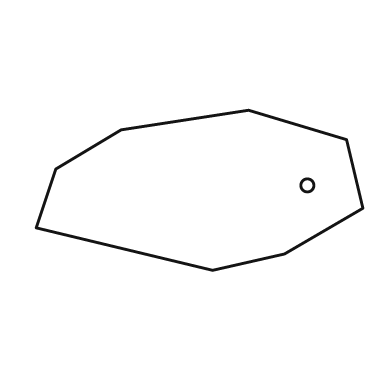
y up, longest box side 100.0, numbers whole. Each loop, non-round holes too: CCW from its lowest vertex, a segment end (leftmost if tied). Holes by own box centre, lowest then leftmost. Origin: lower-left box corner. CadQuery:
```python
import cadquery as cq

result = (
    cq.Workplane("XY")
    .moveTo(54.0, 0.0)
    .lineTo(76.0, 5.0)
    .lineTo(100.0, 19.0)
    .lineTo(95.0, 40.0)
    .lineTo(65.0, 49.0)
    .lineTo(26.0, 43.0)
    .lineTo(6.0, 31.0)
    .lineTo(0.0, 13.0)
    .close()
    .moveTo(83.0, 26.0)
    .circle(2.0)
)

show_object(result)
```